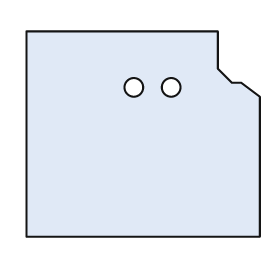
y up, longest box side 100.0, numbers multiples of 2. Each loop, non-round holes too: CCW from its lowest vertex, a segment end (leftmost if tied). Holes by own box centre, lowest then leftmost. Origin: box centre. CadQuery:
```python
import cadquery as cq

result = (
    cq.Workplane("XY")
    .moveTo(-50.0, -44.0)
    .lineTo(50.0, -44.0)
    .lineTo(50.0, 16.0)
    .lineTo(42.0, 22.0)
    .lineTo(38.0, 22.0)
    .lineTo(32.0, 28.0)
    .lineTo(32.0, 44.0)
    .lineTo(-50.0, 44.0)
    .close()
    .moveTo(-4.0, 20.0)
    .circle(4.0)
    .moveTo(12.0, 20.0)
    .circle(4.0)
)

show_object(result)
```